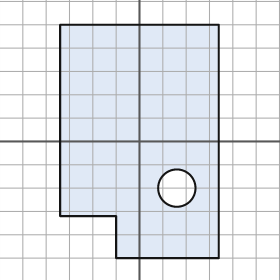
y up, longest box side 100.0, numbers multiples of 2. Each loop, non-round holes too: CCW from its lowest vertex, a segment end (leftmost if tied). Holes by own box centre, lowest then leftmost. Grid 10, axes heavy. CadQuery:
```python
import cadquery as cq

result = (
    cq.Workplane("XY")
    .moveTo(-10.0, -50.0)
    .lineTo(34.0, -50.0)
    .lineTo(34.0, 50.0)
    .lineTo(-34.0, 50.0)
    .lineTo(-34.0, -32.0)
    .lineTo(-10.0, -32.0)
    .close()
    .moveTo(16.0, -20.0)
    .circle(8.0)
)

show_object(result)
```